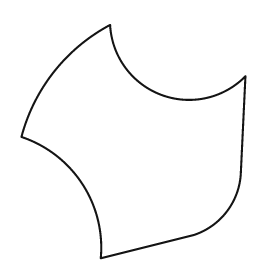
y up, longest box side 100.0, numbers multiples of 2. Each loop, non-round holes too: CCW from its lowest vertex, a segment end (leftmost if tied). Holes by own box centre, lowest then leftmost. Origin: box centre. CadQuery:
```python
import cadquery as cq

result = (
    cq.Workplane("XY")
    .moveTo(-14.0, -50.0)
    .lineTo(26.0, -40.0)
    .threePointArc((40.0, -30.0), (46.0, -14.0))
    .lineTo(48.0, 28.0)
    .threePointArc((12.0, 20.0), (-10.0, 50.0))
    .threePointArc((-34.0, 30.0), (-48.0, 2.0))
    .threePointArc((-22.0, -18.0), (-14.0, -50.0))
    .close()
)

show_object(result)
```